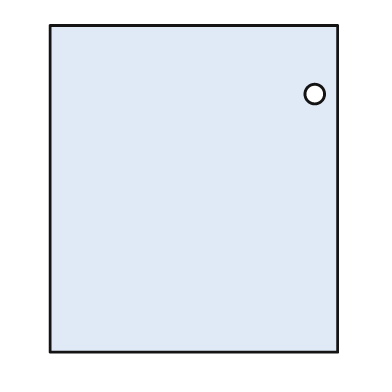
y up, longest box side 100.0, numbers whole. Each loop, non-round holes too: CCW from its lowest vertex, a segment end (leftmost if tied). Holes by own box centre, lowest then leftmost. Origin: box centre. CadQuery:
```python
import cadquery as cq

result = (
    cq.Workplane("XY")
    .moveTo(-44.0, -50.0)
    .lineTo(44.0, -50.0)
    .lineTo(44.0, 50.0)
    .lineTo(-44.0, 50.0)
    .close()
    .moveTo(37.0, 29.0)
    .circle(3.0)
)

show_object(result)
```